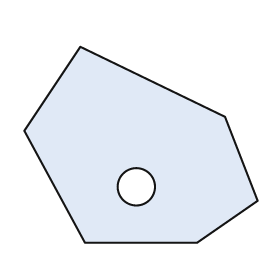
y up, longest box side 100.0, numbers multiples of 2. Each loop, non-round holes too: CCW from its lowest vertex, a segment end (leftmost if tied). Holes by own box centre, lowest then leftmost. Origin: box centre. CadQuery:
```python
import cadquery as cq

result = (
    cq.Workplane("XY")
    .moveTo(-24.0, -42.0)
    .lineTo(24.0, -42.0)
    .lineTo(50.0, -24.0)
    .lineTo(36.0, 12.0)
    .lineTo(-26.0, 42.0)
    .lineTo(-50.0, 6.0)
    .close()
    .moveTo(-2.0, -18.0)
    .circle(8.0)
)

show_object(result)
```